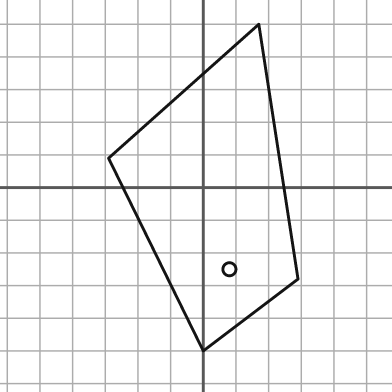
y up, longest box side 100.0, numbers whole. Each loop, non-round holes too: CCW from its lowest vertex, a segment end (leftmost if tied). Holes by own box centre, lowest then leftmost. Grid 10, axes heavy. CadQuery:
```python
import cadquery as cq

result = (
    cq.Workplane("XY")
    .moveTo(0.0, -50.0)
    .lineTo(29.0, -28.0)
    .lineTo(17.0, 50.0)
    .lineTo(-29.0, 9.0)
    .close()
    .moveTo(8.0, -25.0)
    .circle(2.0)
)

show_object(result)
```